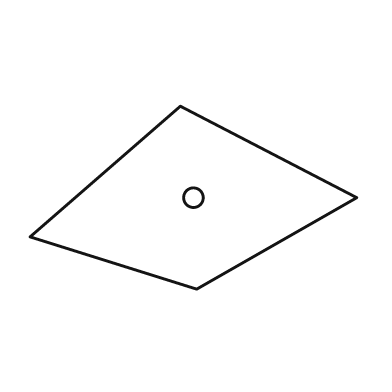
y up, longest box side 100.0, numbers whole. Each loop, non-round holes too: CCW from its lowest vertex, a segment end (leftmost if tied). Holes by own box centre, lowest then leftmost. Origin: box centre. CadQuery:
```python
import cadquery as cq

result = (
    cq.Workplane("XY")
    .moveTo(1.0, -28.0)
    .lineTo(50.0, 0.0)
    .lineTo(-4.0, 28.0)
    .lineTo(-50.0, -12.0)
    .close()
    .moveTo(0.0, 0.0)
    .circle(3.0)
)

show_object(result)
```